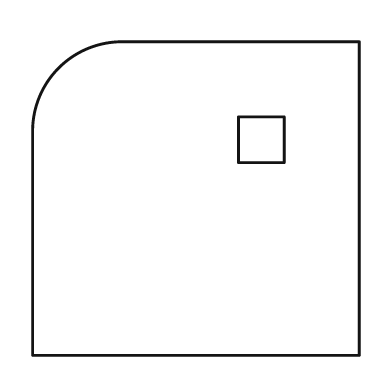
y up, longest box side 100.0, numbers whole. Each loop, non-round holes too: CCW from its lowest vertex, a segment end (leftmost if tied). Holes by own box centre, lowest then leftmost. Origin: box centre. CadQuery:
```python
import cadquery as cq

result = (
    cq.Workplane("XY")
    .moveTo(-50.0, -48.0)
    .lineTo(50.0, -48.0)
    .lineTo(50.0, 48.0)
    .lineTo(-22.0, 48.0)
    .threePointArc((-42.0, 40.0), (-50.0, 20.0))
    .close()
    .moveTo(13.0, 11.0)
    .lineTo(27.0, 11.0)
    .lineTo(27.0, 25.0)
    .lineTo(13.0, 25.0)
    .close()
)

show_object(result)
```